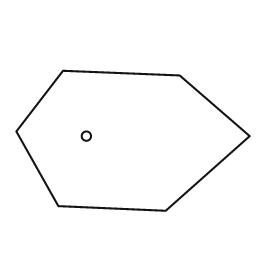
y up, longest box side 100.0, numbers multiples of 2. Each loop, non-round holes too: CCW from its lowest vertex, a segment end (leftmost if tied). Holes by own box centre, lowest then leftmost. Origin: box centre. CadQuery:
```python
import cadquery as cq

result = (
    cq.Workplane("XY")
    .moveTo(14.0, -30.0)
    .lineTo(50.0, 2.0)
    .lineTo(20.0, 28.0)
    .lineTo(-30.0, 30.0)
    .lineTo(-50.0, 4.0)
    .lineTo(-32.0, -28.0)
    .close()
    .moveTo(-20.0, 2.0)
    .circle(2.0)
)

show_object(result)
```